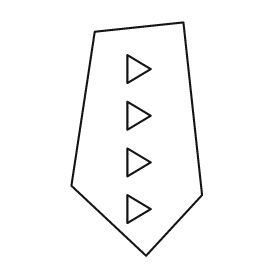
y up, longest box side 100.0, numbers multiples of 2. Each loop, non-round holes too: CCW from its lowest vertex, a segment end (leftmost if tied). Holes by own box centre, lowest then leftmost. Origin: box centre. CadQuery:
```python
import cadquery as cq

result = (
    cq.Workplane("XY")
    .moveTo(4.0, -50.0)
    .lineTo(28.0, -24.0)
    .lineTo(20.0, 50.0)
    .lineTo(-18.0, 46.0)
    .lineTo(-28.0, -20.0)
    .close()
    .moveTo(-4.0, -36.0)
    .lineTo(6.0, -30.0)
    .lineTo(-4.0, -24.0)
    .close()
    .moveTo(-4.0, -16.0)
    .lineTo(6.0, -10.0)
    .lineTo(-4.0, -4.0)
    .close()
    .moveTo(-4.0, 4.0)
    .lineTo(6.0, 10.0)
    .lineTo(-4.0, 16.0)
    .close()
    .moveTo(-4.0, 24.0)
    .lineTo(6.0, 30.0)
    .lineTo(-4.0, 36.0)
    .close()
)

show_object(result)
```